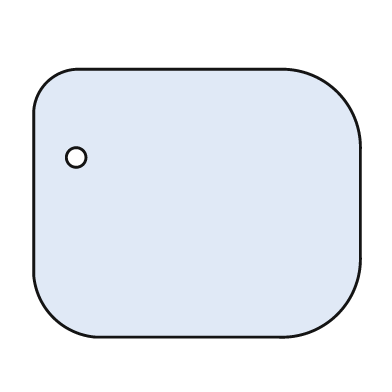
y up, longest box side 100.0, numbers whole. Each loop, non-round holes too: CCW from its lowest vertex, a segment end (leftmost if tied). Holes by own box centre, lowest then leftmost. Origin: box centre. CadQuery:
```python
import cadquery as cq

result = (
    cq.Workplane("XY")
    .moveTo(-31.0, -41.0)
    .lineTo(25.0, -41.0)
    .threePointArc((43.0, -34.0), (50.0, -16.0))
    .lineTo(50.0, 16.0)
    .threePointArc((43.0, 34.0), (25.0, 41.0))
    .lineTo(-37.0, 41.0)
    .threePointArc((-46.0, 37.0), (-50.0, 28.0))
    .lineTo(-50.0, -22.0)
    .threePointArc((-44.0, -35.0), (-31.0, -41.0))
    .close()
    .moveTo(-37.0, 14.0)
    .circle(3.0)
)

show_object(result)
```